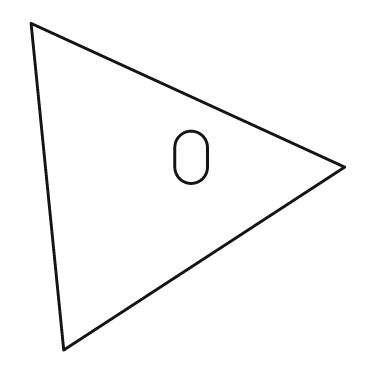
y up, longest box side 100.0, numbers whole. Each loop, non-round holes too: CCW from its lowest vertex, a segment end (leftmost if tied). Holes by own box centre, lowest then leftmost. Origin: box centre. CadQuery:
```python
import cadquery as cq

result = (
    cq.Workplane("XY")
    .moveTo(-38.0, -50.0)
    .lineTo(48.0, 6.0)
    .lineTo(-48.0, 50.0)
    .close()
    .moveTo(-4.0, 6.0)
    .threePointArc((1.0, 1.0), (6.0, 6.0))
    .lineTo(6.0, 12.0)
    .threePointArc((1.0, 17.0), (-4.0, 12.0))
    .close()
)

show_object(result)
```